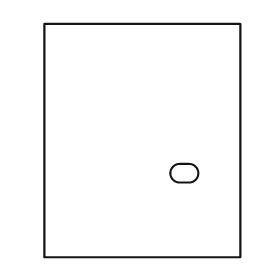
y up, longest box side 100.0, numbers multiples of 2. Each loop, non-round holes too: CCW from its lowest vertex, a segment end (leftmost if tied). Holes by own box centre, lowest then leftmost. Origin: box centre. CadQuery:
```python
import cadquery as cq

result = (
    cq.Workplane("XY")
    .moveTo(-42.0, -50.0)
    .lineTo(42.0, -50.0)
    .lineTo(42.0, 50.0)
    .lineTo(-42.0, 50.0)
    .close()
    .moveTo(16.0, -18.0)
    .lineTo(20.0, -18.0)
    .threePointArc((24.0, -14.0), (20.0, -10.0))
    .lineTo(16.0, -10.0)
    .threePointArc((12.0, -14.0), (16.0, -18.0))
    .close()
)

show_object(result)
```